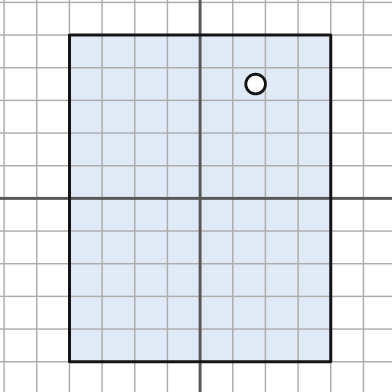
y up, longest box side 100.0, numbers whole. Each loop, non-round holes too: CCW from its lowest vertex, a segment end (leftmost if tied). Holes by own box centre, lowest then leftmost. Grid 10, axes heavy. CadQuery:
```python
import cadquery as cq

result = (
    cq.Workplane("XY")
    .moveTo(-40.0, -50.0)
    .lineTo(40.0, -50.0)
    .lineTo(40.0, 50.0)
    .lineTo(-40.0, 50.0)
    .close()
    .moveTo(17.0, 35.0)
    .circle(3.0)
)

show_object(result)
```